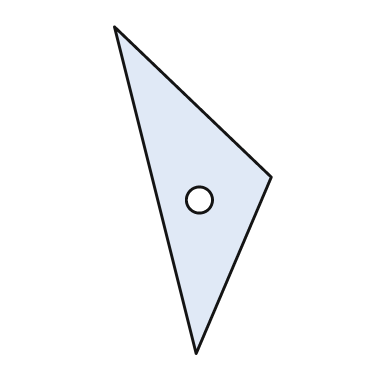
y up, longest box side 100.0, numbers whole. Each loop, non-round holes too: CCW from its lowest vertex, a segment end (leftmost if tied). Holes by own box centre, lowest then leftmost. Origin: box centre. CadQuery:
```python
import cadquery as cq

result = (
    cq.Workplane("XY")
    .moveTo(1.0, -50.0)
    .lineTo(24.0, 4.0)
    .lineTo(-24.0, 50.0)
    .close()
    .moveTo(2.0, -3.0)
    .circle(4.0)
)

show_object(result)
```